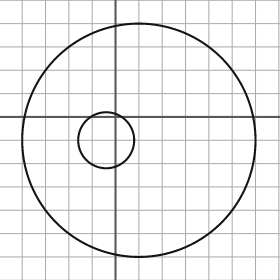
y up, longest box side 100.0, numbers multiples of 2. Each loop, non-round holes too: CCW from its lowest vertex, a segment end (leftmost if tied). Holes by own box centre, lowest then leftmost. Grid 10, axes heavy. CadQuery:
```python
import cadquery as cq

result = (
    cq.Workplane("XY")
    .moveTo(10.0, -10.0)
    .circle(50.0)
    .moveTo(-4.0, -10.0)
    .circle(12.0)
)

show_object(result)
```